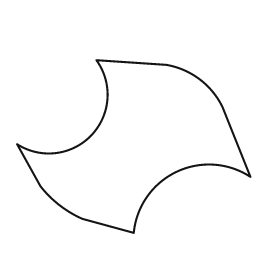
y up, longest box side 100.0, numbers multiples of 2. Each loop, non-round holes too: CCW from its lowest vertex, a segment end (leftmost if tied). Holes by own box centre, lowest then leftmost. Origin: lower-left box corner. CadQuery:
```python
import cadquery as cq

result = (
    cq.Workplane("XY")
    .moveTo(50.0, 0.0)
    .threePointArc((68.0, 26.0), (100.0, 24.0))
    .lineTo(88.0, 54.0)
    .threePointArc((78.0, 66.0), (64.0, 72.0))
    .lineTo(34.0, 74.0)
    .threePointArc((32.0, 42.0), (0.0, 38.0))
    .lineTo(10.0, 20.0)
    .threePointArc((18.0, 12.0), (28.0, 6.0))
    .close()
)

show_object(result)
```